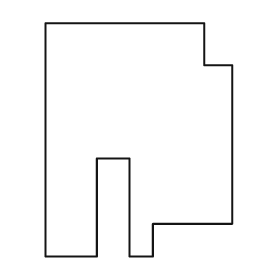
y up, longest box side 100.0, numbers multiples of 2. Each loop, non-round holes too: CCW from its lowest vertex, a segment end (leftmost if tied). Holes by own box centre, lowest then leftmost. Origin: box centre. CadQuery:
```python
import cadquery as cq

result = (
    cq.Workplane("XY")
    .moveTo(-40.0, -50.0)
    .lineTo(-18.0, -50.0)
    .lineTo(-18.0, -8.0)
    .lineTo(-4.0, -8.0)
    .lineTo(-4.0, -50.0)
    .lineTo(6.0, -50.0)
    .lineTo(6.0, -36.0)
    .lineTo(40.0, -36.0)
    .lineTo(40.0, 32.0)
    .lineTo(28.0, 32.0)
    .lineTo(28.0, 50.0)
    .lineTo(-40.0, 50.0)
    .close()
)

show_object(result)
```